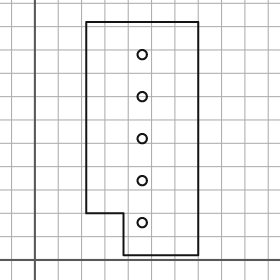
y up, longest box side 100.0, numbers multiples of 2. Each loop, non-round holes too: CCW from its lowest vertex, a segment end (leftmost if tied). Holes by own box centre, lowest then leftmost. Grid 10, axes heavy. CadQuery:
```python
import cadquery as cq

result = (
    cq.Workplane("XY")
    .moveTo(38.0, 2.0)
    .lineTo(70.0, 2.0)
    .lineTo(70.0, 102.0)
    .lineTo(22.0, 102.0)
    .lineTo(22.0, 20.0)
    .lineTo(38.0, 20.0)
    .close()
    .moveTo(46.0, 16.0)
    .circle(2.0)
    .moveTo(46.0, 34.0)
    .circle(2.0)
    .moveTo(46.0, 52.0)
    .circle(2.0)
    .moveTo(46.0, 70.0)
    .circle(2.0)
    .moveTo(46.0, 88.0)
    .circle(2.0)
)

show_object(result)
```